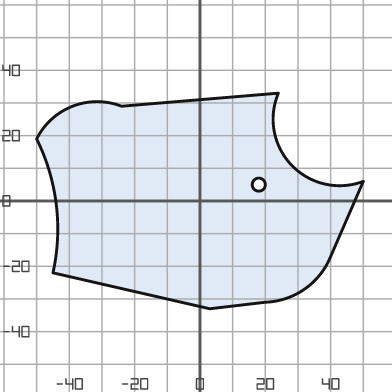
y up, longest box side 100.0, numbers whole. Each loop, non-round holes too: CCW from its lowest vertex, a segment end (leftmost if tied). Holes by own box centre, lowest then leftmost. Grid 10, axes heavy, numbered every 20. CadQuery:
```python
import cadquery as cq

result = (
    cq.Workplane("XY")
    .moveTo(3.0, -33.0)
    .lineTo(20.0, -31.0)
    .threePointArc((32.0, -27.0), (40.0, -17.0))
    .lineTo(50.0, 6.0)
    .threePointArc((28.0, 11.0), (24.0, 33.0))
    .lineTo(-24.0, 29.0)
    .threePointArc((-39.0, 29.0), (-50.0, 19.0))
    .threePointArc((-44.0, -1.0), (-45.0, -22.0))
    .close()
    .moveTo(18.0, 5.0)
    .circle(2.0)
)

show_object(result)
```